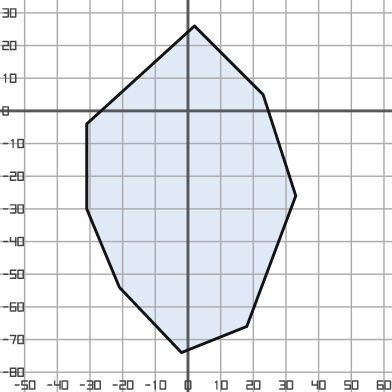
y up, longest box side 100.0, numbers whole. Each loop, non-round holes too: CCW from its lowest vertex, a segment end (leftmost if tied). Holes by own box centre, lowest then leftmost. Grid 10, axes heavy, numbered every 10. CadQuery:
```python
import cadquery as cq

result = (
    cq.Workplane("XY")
    .moveTo(-2.0, -74.0)
    .lineTo(18.0, -66.0)
    .lineTo(33.0, -26.0)
    .lineTo(23.0, 5.0)
    .lineTo(2.0, 26.0)
    .lineTo(-31.0, -4.0)
    .lineTo(-31.0, -30.0)
    .lineTo(-21.0, -54.0)
    .close()
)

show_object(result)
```